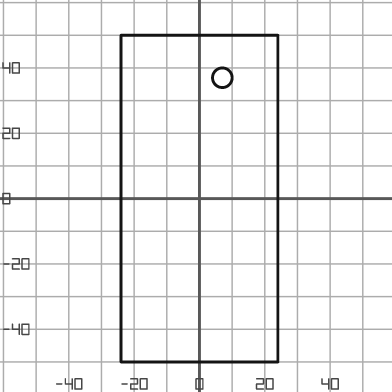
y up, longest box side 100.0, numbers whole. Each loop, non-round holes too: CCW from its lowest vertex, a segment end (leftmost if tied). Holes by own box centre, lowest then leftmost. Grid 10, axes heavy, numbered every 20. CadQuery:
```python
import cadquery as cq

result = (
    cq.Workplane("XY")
    .moveTo(-24.0, -50.0)
    .lineTo(24.0, -50.0)
    .lineTo(24.0, 50.0)
    .lineTo(-24.0, 50.0)
    .close()
    .moveTo(7.0, 37.0)
    .circle(3.0)
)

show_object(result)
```